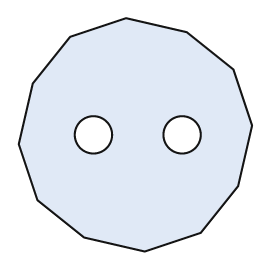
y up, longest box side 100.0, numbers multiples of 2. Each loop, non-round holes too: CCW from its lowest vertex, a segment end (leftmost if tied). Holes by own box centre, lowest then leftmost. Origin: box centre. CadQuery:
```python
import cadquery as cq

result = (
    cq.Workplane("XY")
    .moveTo(4.0, -50.0)
    .lineTo(28.0, -42.0)
    .lineTo(44.0, -22.0)
    .lineTo(50.0, 4.0)
    .lineTo(42.0, 28.0)
    .lineTo(22.0, 44.0)
    .lineTo(-4.0, 50.0)
    .lineTo(-28.0, 42.0)
    .lineTo(-44.0, 22.0)
    .lineTo(-50.0, -4.0)
    .lineTo(-42.0, -28.0)
    .lineTo(-22.0, -44.0)
    .close()
    .moveTo(-18.0, 0.0)
    .circle(8.0)
    .moveTo(20.0, 0.0)
    .circle(8.0)
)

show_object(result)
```